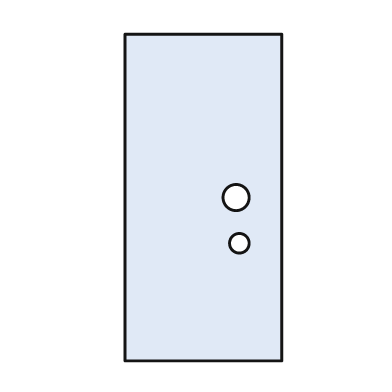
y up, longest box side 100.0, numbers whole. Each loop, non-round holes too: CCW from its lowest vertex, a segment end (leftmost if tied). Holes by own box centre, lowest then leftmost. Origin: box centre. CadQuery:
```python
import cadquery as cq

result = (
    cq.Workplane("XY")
    .moveTo(-24.0, -50.0)
    .lineTo(24.0, -50.0)
    .lineTo(24.0, 50.0)
    .lineTo(-24.0, 50.0)
    .close()
    .moveTo(11.0, -14.0)
    .circle(3.0)
    .moveTo(10.0, 0.0)
    .circle(4.0)
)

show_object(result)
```